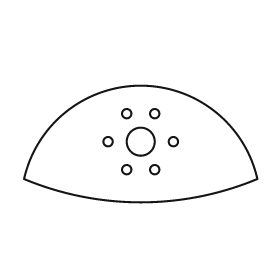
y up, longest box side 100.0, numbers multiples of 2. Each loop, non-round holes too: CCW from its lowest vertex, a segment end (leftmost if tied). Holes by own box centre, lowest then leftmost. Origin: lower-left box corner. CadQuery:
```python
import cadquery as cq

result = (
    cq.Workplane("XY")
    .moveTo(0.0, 10.0)
    .threePointArc((50.0, 0.0), (100.0, 10.0))
    .threePointArc((50.0, 50.0), (0.0, 10.0))
    .close()
    .moveTo(44.0, 14.0)
    .circle(2.0)
    .moveTo(56.0, 14.0)
    .circle(2.0)
    .moveTo(36.0, 26.0)
    .circle(2.0)
    .moveTo(50.0, 26.0)
    .circle(6.0)
    .moveTo(64.0, 26.0)
    .circle(2.0)
    .moveTo(44.0, 38.0)
    .circle(2.0)
    .moveTo(56.0, 38.0)
    .circle(2.0)
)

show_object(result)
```